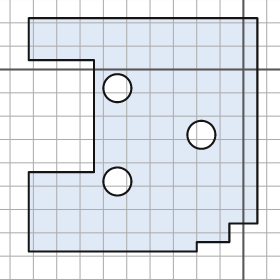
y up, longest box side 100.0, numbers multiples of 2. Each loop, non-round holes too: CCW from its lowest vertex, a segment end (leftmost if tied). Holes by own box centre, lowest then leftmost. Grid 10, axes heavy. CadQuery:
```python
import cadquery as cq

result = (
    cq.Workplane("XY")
    .moveTo(-92.0, -78.0)
    .lineTo(-20.0, -78.0)
    .lineTo(-20.0, -74.0)
    .lineTo(-6.0, -74.0)
    .lineTo(-6.0, -66.0)
    .lineTo(6.0, -66.0)
    .lineTo(6.0, 22.0)
    .lineTo(-92.0, 22.0)
    .lineTo(-92.0, 4.0)
    .lineTo(-64.0, 4.0)
    .lineTo(-64.0, -44.0)
    .lineTo(-92.0, -44.0)
    .close()
    .moveTo(-54.0, -48.0)
    .circle(6.0)
    .moveTo(-18.0, -28.0)
    .circle(6.0)
    .moveTo(-54.0, -8.0)
    .circle(6.0)
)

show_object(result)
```